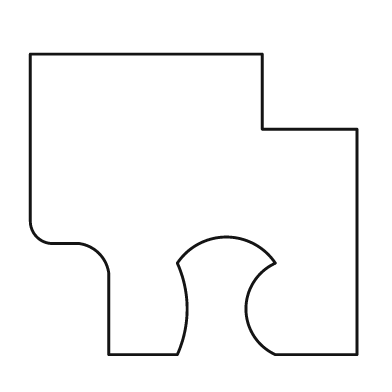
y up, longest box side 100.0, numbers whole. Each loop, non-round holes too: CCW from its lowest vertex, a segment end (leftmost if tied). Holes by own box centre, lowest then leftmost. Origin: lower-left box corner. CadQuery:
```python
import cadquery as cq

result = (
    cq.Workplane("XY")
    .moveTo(24.0, 0.0)
    .lineTo(45.0, 0.0)
    .threePointArc((48.0, 14.0), (45.0, 28.0))
    .threePointArc((60.0, 36.0), (75.0, 28.0))
    .threePointArc((66.0, 14.0), (75.0, 0.0))
    .lineTo(100.0, 0.0)
    .lineTo(100.0, 69.0)
    .lineTo(71.0, 69.0)
    .lineTo(71.0, 92.0)
    .lineTo(0.0, 92.0)
    .lineTo(0.0, 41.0)
    .threePointArc((2.0, 36.0), (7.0, 34.0))
    .lineTo(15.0, 34.0)
    .threePointArc((21.0, 31.0), (24.0, 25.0))
    .close()
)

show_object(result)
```